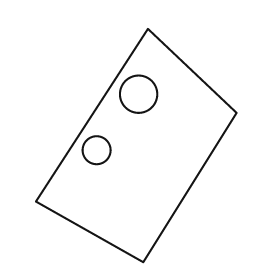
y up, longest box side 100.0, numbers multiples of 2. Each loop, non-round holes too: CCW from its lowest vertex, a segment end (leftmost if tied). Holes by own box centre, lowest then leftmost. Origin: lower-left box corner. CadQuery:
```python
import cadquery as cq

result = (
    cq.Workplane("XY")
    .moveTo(46.0, 0.0)
    .lineTo(86.0, 64.0)
    .lineTo(48.0, 100.0)
    .lineTo(0.0, 26.0)
    .close()
    .moveTo(26.0, 48.0)
    .circle(6.0)
    .moveTo(44.0, 72.0)
    .circle(8.0)
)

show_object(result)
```